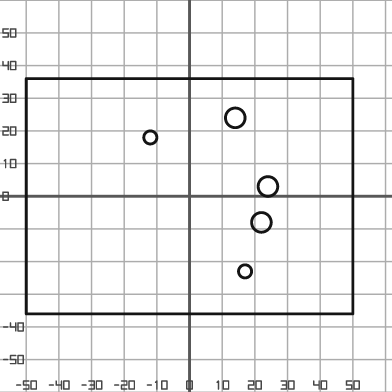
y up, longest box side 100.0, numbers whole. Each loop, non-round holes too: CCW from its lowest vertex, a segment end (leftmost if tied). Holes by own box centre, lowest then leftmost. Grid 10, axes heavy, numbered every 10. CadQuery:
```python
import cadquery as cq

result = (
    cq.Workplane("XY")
    .moveTo(-50.0, -36.0)
    .lineTo(50.0, -36.0)
    .lineTo(50.0, 36.0)
    .lineTo(-50.0, 36.0)
    .close()
    .moveTo(17.0, -23.0)
    .circle(2.0)
    .moveTo(22.0, -8.0)
    .circle(3.0)
    .moveTo(24.0, 3.0)
    .circle(3.0)
    .moveTo(-12.0, 18.0)
    .circle(2.0)
    .moveTo(14.0, 24.0)
    .circle(3.0)
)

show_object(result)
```